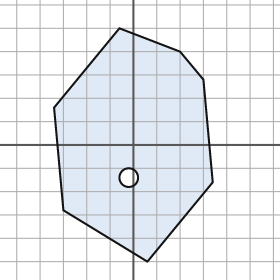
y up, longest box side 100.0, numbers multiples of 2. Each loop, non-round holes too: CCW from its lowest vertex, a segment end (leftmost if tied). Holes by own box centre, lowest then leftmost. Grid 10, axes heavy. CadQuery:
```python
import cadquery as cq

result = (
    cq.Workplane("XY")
    .moveTo(6.0, -50.0)
    .lineTo(34.0, -16.0)
    .lineTo(30.0, 28.0)
    .lineTo(20.0, 40.0)
    .lineTo(-6.0, 50.0)
    .lineTo(-34.0, 16.0)
    .lineTo(-30.0, -28.0)
    .close()
    .moveTo(-2.0, -14.0)
    .circle(4.0)
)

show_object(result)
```